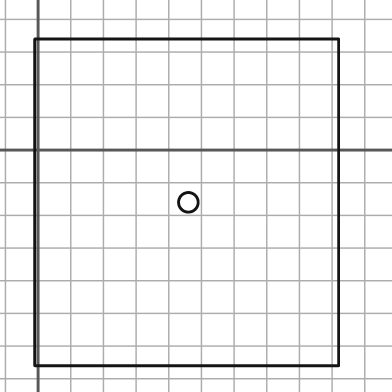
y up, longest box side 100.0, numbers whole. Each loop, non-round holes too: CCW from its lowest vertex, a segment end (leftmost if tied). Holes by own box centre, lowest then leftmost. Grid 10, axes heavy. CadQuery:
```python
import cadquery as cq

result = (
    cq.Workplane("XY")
    .moveTo(-1.0, -66.0)
    .lineTo(92.0, -66.0)
    .lineTo(92.0, 34.0)
    .lineTo(-1.0, 34.0)
    .close()
    .moveTo(46.0, -16.0)
    .circle(3.0)
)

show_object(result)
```